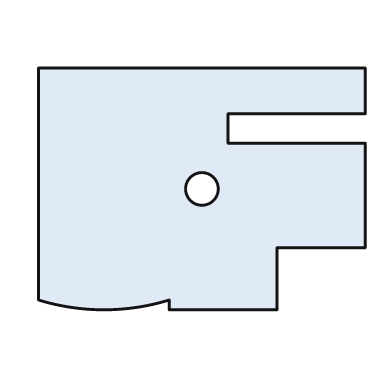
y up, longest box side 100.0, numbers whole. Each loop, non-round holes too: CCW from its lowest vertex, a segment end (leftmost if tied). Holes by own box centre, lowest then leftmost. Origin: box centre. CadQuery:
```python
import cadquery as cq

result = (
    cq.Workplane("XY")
    .moveTo(-10.0, -37.0)
    .lineTo(23.0, -37.0)
    .lineTo(23.0, -18.0)
    .lineTo(50.0, -18.0)
    .lineTo(50.0, 14.0)
    .lineTo(8.0, 14.0)
    .lineTo(8.0, 23.0)
    .lineTo(50.0, 23.0)
    .lineTo(50.0, 37.0)
    .lineTo(-50.0, 37.0)
    .lineTo(-50.0, -34.0)
    .threePointArc((-30.0, -37.0), (-10.0, -34.0))
    .close()
    .moveTo(0.0, 0.0)
    .circle(5.0)
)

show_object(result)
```